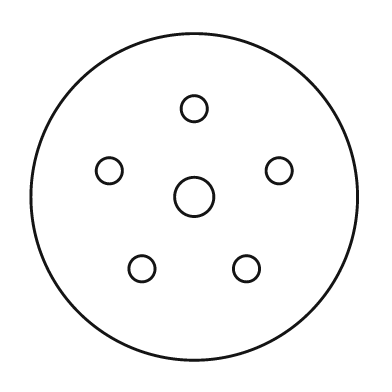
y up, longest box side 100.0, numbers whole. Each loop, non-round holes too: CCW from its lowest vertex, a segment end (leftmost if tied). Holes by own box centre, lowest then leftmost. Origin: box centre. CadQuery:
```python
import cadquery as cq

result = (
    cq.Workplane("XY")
    .moveTo(0.0, 0.0)
    .circle(50.0)
    .moveTo(-16.0, -22.0)
    .circle(4.0)
    .moveTo(16.0, -22.0)
    .circle(4.0)
    .moveTo(0.0, 0.0)
    .circle(6.0)
    .moveTo(-26.0, 8.0)
    .circle(4.0)
    .moveTo(26.0, 8.0)
    .circle(4.0)
    .moveTo(0.0, 27.0)
    .circle(4.0)
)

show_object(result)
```